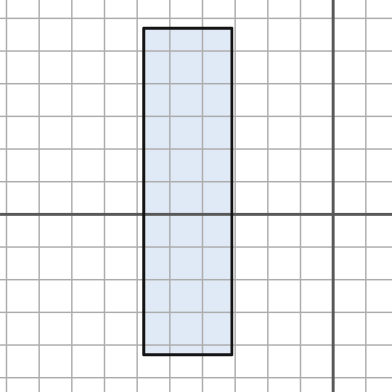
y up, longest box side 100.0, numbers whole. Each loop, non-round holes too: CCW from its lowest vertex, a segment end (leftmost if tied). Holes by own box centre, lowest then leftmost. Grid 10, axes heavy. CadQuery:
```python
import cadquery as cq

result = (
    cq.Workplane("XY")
    .moveTo(-58.0, -43.0)
    .lineTo(-31.0, -43.0)
    .lineTo(-31.0, 57.0)
    .lineTo(-58.0, 57.0)
    .close()
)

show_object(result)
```